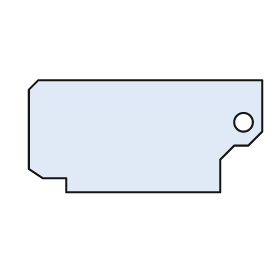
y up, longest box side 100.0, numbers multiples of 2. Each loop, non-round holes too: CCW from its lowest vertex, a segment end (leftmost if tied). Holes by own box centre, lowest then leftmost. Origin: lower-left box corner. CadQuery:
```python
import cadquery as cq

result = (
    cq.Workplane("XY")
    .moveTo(16.0, 0.0)
    .lineTo(82.0, 0.0)
    .lineTo(82.0, 14.0)
    .lineTo(88.0, 20.0)
    .lineTo(94.0, 20.0)
    .lineTo(100.0, 26.0)
    .lineTo(100.0, 48.0)
    .lineTo(4.0, 48.0)
    .lineTo(0.0, 44.0)
    .lineTo(0.0, 10.0)
    .lineTo(6.0, 6.0)
    .lineTo(16.0, 6.0)
    .close()
    .moveTo(92.0, 30.0)
    .circle(4.0)
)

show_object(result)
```